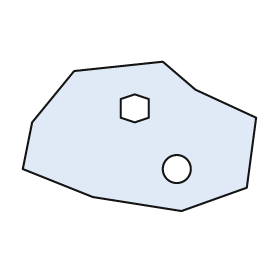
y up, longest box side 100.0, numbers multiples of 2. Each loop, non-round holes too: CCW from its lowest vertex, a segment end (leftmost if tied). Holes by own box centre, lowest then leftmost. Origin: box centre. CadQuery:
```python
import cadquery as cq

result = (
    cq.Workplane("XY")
    .moveTo(18.0, -32.0)
    .lineTo(46.0, -22.0)
    .lineTo(50.0, 8.0)
    .lineTo(24.0, 20.0)
    .lineTo(10.0, 32.0)
    .lineTo(-28.0, 28.0)
    .lineTo(-46.0, 6.0)
    .lineTo(-50.0, -14.0)
    .lineTo(-20.0, -26.0)
    .close()
    .moveTo(16.0, -14.0)
    .circle(6.0)
    .moveTo(-2.0, 6.0)
    .lineTo(4.0, 8.0)
    .lineTo(4.0, 16.0)
    .lineTo(-2.0, 18.0)
    .lineTo(-8.0, 16.0)
    .lineTo(-8.0, 8.0)
    .close()
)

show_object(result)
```